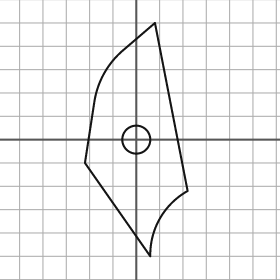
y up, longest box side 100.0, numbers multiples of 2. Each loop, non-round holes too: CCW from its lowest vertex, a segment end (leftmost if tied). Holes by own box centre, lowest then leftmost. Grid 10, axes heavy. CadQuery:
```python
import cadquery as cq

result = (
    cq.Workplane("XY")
    .moveTo(6.0, -50.0)
    .threePointArc((10.0, -34.0), (22.0, -22.0))
    .lineTo(8.0, 50.0)
    .lineTo(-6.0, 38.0)
    .threePointArc((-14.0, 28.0), (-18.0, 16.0))
    .lineTo(-22.0, -10.0)
    .close()
    .moveTo(0.0, 0.0)
    .circle(6.0)
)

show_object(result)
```